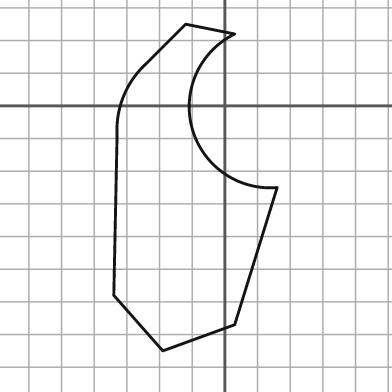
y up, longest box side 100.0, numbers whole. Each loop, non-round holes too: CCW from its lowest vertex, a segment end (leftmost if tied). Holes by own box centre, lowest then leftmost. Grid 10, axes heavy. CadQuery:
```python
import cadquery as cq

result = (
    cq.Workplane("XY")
    .moveTo(-19.0, -75.0)
    .lineTo(3.0, -67.0)
    .lineTo(16.0, -25.0)
    .threePointArc((-10.0, -7.0), (3.0, 22.0))
    .lineTo(-12.0, 25.0)
    .lineTo(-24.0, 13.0)
    .threePointArc((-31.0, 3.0), (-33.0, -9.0))
    .lineTo(-34.0, -58.0)
    .close()
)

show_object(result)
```